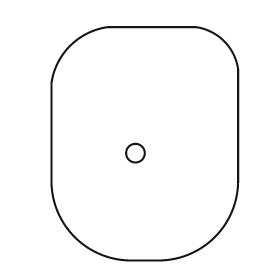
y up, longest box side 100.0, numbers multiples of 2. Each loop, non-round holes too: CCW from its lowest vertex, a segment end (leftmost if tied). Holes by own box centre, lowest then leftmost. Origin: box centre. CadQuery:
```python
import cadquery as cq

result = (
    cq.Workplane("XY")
    .moveTo(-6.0, -50.0)
    .lineTo(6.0, -50.0)
    .threePointArc((30.0, -40.0), (40.0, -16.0))
    .lineTo(40.0, 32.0)
    .threePointArc((34.0, 44.0), (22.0, 50.0))
    .lineTo(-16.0, 50.0)
    .threePointArc((-32.0, 42.0), (-40.0, 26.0))
    .lineTo(-40.0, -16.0)
    .threePointArc((-30.0, -40.0), (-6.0, -50.0))
    .close()
    .moveTo(-4.0, -4.0)
    .circle(4.0)
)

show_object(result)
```